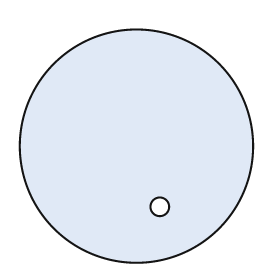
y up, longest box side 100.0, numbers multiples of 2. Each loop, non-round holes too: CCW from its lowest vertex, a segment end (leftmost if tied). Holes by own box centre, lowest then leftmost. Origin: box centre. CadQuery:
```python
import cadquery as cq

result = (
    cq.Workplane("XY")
    .moveTo(0.0, 0.0)
    .circle(50.0)
    .moveTo(10.0, -26.0)
    .circle(4.0)
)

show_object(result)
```